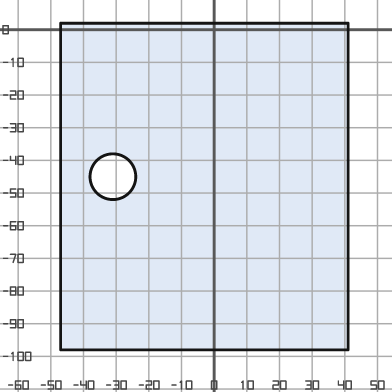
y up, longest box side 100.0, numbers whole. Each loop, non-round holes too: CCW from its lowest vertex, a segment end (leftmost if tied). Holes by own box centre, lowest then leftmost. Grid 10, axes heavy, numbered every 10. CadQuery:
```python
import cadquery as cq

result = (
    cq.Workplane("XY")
    .moveTo(-47.0, -98.0)
    .lineTo(41.0, -98.0)
    .lineTo(41.0, 2.0)
    .lineTo(-47.0, 2.0)
    .close()
    .moveTo(-31.0, -45.0)
    .circle(7.0)
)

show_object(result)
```